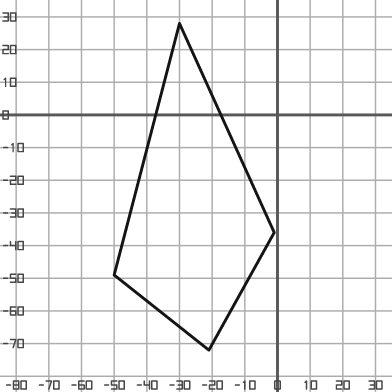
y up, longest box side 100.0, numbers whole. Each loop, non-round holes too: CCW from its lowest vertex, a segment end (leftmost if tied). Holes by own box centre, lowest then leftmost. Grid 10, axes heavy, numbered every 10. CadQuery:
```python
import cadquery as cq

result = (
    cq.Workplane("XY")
    .moveTo(-21.0, -72.0)
    .lineTo(-1.0, -36.0)
    .lineTo(-30.0, 28.0)
    .lineTo(-50.0, -49.0)
    .close()
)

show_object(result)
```